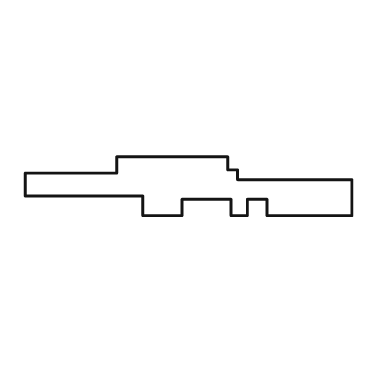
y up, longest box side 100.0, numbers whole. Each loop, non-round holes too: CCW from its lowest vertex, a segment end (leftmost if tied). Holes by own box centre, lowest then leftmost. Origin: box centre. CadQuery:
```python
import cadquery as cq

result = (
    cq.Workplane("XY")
    .moveTo(-14.0, -9.0)
    .lineTo(-2.0, -9.0)
    .lineTo(-2.0, -4.0)
    .lineTo(13.0, -4.0)
    .lineTo(13.0, -9.0)
    .lineTo(18.0, -9.0)
    .lineTo(18.0, -4.0)
    .lineTo(24.0, -4.0)
    .lineTo(24.0, -9.0)
    .lineTo(50.0, -9.0)
    .lineTo(50.0, 2.0)
    .lineTo(15.0, 2.0)
    .lineTo(15.0, 5.0)
    .lineTo(12.0, 5.0)
    .lineTo(12.0, 9.0)
    .lineTo(-22.0, 9.0)
    .lineTo(-22.0, 4.0)
    .lineTo(-50.0, 4.0)
    .lineTo(-50.0, -3.0)
    .lineTo(-14.0, -3.0)
    .close()
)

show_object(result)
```